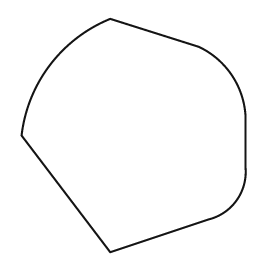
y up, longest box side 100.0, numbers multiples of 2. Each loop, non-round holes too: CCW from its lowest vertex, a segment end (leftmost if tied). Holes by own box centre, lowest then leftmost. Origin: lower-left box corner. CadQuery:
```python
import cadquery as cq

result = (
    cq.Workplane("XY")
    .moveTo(38.0, 0.0)
    .lineTo(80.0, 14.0)
    .threePointArc((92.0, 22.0), (96.0, 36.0))
    .lineTo(96.0, 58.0)
    .threePointArc((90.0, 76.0), (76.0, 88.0))
    .lineTo(38.0, 100.0)
    .threePointArc((12.0, 80.0), (0.0, 50.0))
    .close()
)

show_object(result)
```